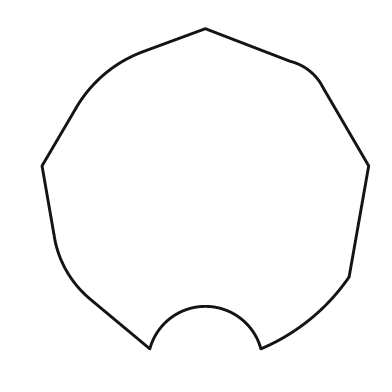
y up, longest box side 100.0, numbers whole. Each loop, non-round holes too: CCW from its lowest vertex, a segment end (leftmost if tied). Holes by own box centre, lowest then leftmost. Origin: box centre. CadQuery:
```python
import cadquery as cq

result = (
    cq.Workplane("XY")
    .moveTo(-17.0, -49.0)
    .threePointArc((0.0, -36.0), (17.0, -49.0))
    .threePointArc((32.0, -40.0), (44.0, -27.0))
    .lineTo(50.0, 7.0)
    .lineTo(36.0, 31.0)
    .threePointArc((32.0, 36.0), (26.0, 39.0))
    .lineTo(0.0, 49.0)
    .lineTo(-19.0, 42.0)
    .threePointArc((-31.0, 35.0), (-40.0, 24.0))
    .lineTo(-50.0, 7.0)
    .lineTo(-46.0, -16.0)
    .threePointArc((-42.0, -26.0), (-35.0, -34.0))
    .close()
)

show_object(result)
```